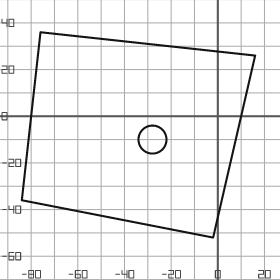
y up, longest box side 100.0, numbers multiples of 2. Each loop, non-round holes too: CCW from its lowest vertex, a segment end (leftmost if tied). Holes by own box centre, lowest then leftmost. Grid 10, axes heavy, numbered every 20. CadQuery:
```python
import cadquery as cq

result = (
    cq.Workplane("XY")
    .moveTo(-2.0, -52.0)
    .lineTo(16.0, 26.0)
    .lineTo(-76.0, 36.0)
    .lineTo(-84.0, -36.0)
    .close()
    .moveTo(-28.0, -10.0)
    .circle(6.0)
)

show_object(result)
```